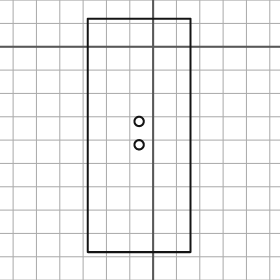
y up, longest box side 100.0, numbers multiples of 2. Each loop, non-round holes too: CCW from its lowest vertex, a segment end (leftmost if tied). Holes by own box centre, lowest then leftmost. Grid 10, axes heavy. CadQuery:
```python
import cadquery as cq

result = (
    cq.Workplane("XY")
    .moveTo(-28.0, -88.0)
    .lineTo(16.0, -88.0)
    .lineTo(16.0, 12.0)
    .lineTo(-28.0, 12.0)
    .close()
    .moveTo(-6.0, -42.0)
    .circle(2.0)
    .moveTo(-6.0, -32.0)
    .circle(2.0)
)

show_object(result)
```